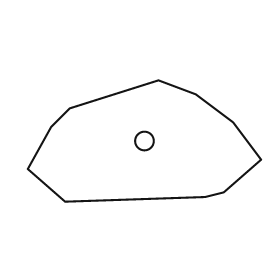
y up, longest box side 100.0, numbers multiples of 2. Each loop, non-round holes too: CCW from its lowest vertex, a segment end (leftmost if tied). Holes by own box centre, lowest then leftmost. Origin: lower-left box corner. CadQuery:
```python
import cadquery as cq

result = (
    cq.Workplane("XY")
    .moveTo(16.0, 0.0)
    .lineTo(76.0, 2.0)
    .lineTo(84.0, 4.0)
    .lineTo(100.0, 18.0)
    .lineTo(88.0, 34.0)
    .lineTo(72.0, 46.0)
    .lineTo(56.0, 52.0)
    .lineTo(18.0, 40.0)
    .lineTo(10.0, 32.0)
    .lineTo(0.0, 14.0)
    .close()
    .moveTo(50.0, 26.0)
    .circle(4.0)
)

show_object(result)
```